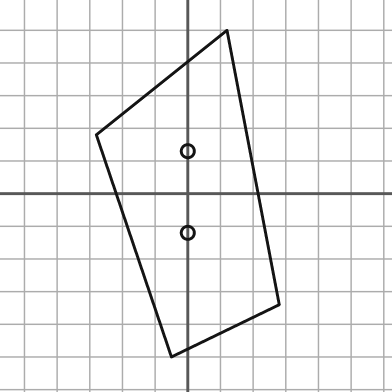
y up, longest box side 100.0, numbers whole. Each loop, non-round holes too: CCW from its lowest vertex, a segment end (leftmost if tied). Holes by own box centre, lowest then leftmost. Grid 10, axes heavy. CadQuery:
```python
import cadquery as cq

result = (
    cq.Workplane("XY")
    .moveTo(-5.0, -50.0)
    .lineTo(28.0, -34.0)
    .lineTo(12.0, 50.0)
    .lineTo(-28.0, 18.0)
    .close()
    .moveTo(0.0, -12.0)
    .circle(2.0)
    .moveTo(0.0, 13.0)
    .circle(2.0)
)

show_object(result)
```